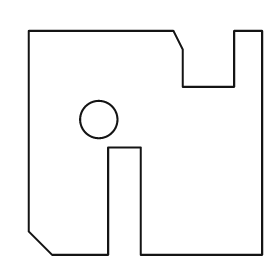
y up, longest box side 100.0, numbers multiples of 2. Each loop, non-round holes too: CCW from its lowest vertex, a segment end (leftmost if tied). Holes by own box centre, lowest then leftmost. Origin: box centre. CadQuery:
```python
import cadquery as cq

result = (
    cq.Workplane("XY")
    .moveTo(-40.0, -48.0)
    .lineTo(-16.0, -48.0)
    .lineTo(-16.0, -2.0)
    .lineTo(-2.0, -2.0)
    .lineTo(-2.0, -48.0)
    .lineTo(50.0, -48.0)
    .lineTo(50.0, 48.0)
    .lineTo(38.0, 48.0)
    .lineTo(38.0, 24.0)
    .lineTo(16.0, 24.0)
    .lineTo(16.0, 40.0)
    .lineTo(12.0, 48.0)
    .lineTo(-50.0, 48.0)
    .lineTo(-50.0, -38.0)
    .close()
    .moveTo(-20.0, 10.0)
    .circle(8.0)
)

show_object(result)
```